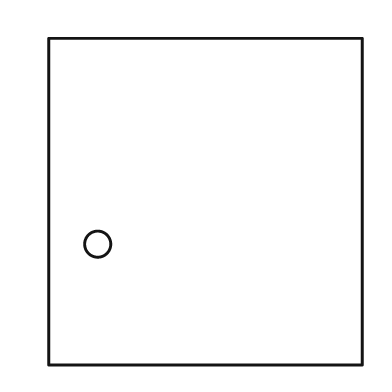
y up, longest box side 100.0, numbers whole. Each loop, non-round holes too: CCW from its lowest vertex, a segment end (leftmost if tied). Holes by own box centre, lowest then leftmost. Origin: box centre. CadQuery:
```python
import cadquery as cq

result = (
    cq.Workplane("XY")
    .moveTo(-48.0, -50.0)
    .lineTo(48.0, -50.0)
    .lineTo(48.0, 50.0)
    .lineTo(-48.0, 50.0)
    .close()
    .moveTo(-33.0, -13.0)
    .circle(4.0)
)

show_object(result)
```